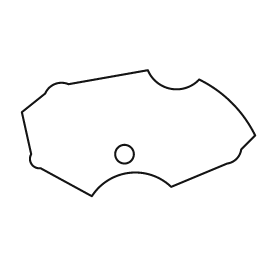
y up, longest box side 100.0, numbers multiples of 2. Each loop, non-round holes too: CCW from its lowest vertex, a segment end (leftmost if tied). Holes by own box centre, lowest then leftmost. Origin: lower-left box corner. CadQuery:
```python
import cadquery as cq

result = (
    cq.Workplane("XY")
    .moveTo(30.0, 0.0)
    .threePointArc((46.0, 10.0), (64.0, 4.0))
    .lineTo(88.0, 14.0)
    .threePointArc((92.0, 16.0), (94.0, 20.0))
    .lineTo(100.0, 26.0)
    .threePointArc((90.0, 40.0), (76.0, 50.0))
    .threePointArc((64.0, 46.0), (54.0, 54.0))
    .lineTo(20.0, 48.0)
    .threePointArc((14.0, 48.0), (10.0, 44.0))
    .lineTo(0.0, 36.0)
    .lineTo(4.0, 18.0)
    .threePointArc((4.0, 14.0), (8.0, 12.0))
    .close()
    .moveTo(44.0, 18.0)
    .circle(4.0)
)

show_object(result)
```